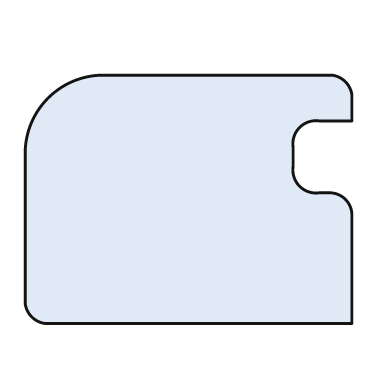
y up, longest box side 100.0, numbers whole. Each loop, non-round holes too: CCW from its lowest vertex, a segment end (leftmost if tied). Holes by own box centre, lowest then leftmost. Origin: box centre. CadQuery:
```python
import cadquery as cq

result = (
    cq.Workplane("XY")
    .moveTo(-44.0, -38.0)
    .lineTo(50.0, -38.0)
    .lineTo(50.0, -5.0)
    .threePointArc((48.0, 0.0), (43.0, 2.0))
    .lineTo(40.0, 2.0)
    .threePointArc((34.0, 4.0), (32.0, 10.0))
    .lineTo(32.0, 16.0)
    .threePointArc((34.0, 22.0), (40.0, 24.0))
    .lineTo(50.0, 24.0)
    .lineTo(50.0, 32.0)
    .threePointArc((48.0, 36.0), (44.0, 38.0))
    .lineTo(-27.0, 38.0)
    .threePointArc((-43.0, 31.0), (-50.0, 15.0))
    .lineTo(-50.0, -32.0)
    .threePointArc((-48.0, -36.0), (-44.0, -38.0))
    .close()
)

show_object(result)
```